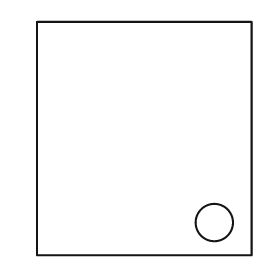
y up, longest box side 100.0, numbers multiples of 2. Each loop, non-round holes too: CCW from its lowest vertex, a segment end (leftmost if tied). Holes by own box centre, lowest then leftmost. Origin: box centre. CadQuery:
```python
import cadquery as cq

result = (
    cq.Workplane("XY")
    .moveTo(-46.0, -50.0)
    .lineTo(46.0, -50.0)
    .lineTo(46.0, 50.0)
    .lineTo(-46.0, 50.0)
    .close()
    .moveTo(30.0, -36.0)
    .circle(8.0)
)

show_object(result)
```